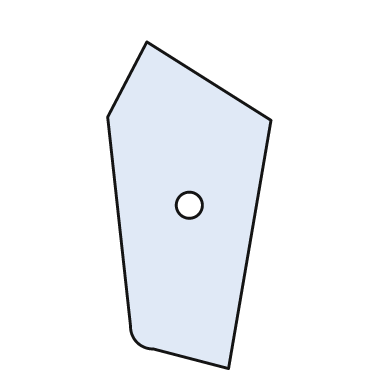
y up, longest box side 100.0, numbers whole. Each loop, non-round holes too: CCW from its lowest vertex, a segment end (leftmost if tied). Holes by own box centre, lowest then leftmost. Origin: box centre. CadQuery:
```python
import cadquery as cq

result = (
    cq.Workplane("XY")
    .moveTo(12.0, -50.0)
    .lineTo(25.0, 26.0)
    .lineTo(-13.0, 50.0)
    .lineTo(-25.0, 27.0)
    .lineTo(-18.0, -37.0)
    .threePointArc((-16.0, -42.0), (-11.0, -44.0))
    .close()
    .moveTo(0.0, 0.0)
    .circle(4.0)
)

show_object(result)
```